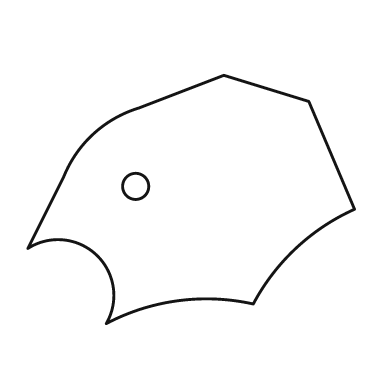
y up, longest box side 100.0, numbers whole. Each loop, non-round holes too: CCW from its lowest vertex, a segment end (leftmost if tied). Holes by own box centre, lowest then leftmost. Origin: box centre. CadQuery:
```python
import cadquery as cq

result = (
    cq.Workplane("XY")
    .moveTo(-26.0, -38.0)
    .threePointArc((-4.0, -31.0), (19.0, -32.0))
    .threePointArc((32.0, -15.0), (50.0, -3.0))
    .lineTo(36.0, 30.0)
    .lineTo(10.0, 38.0)
    .lineTo(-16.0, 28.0)
    .threePointArc((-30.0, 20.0), (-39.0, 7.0))
    .lineTo(-50.0, -15.0)
    .threePointArc((-29.0, -17.0), (-26.0, -38.0))
    .close()
    .moveTo(-17.0, 4.0)
    .circle(4.0)
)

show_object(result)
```